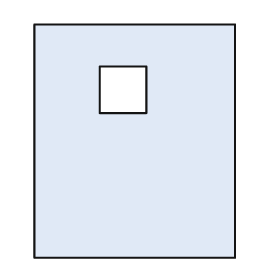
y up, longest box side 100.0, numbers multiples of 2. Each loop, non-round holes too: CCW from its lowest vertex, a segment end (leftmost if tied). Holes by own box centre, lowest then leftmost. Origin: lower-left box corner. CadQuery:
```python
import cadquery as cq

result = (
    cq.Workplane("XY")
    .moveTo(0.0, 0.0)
    .lineTo(86.0, 0.0)
    .lineTo(86.0, 100.0)
    .lineTo(0.0, 100.0)
    .close()
    .moveTo(28.0, 62.0)
    .lineTo(48.0, 62.0)
    .lineTo(48.0, 82.0)
    .lineTo(28.0, 82.0)
    .close()
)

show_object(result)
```